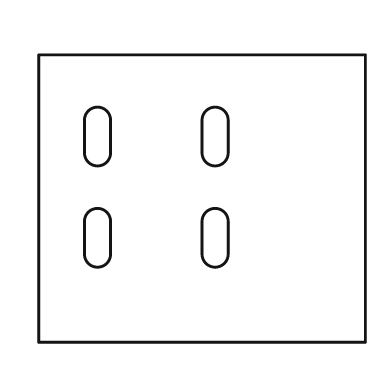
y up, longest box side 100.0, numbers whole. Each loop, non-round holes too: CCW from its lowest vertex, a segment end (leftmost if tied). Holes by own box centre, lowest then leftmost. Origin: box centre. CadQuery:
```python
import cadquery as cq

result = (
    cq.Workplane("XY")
    .moveTo(-50.0, -44.0)
    .lineTo(50.0, -44.0)
    .lineTo(50.0, 44.0)
    .lineTo(-50.0, 44.0)
    .close()
    .moveTo(-36.0, -17.0)
    .threePointArc((-32.0, -21.0), (-28.0, -17.0))
    .lineTo(-28.0, -7.0)
    .threePointArc((-32.0, -3.0), (-36.0, -7.0))
    .close()
    .moveTo(0.0, -17.0)
    .threePointArc((4.0, -21.0), (8.0, -17.0))
    .lineTo(8.0, -7.0)
    .threePointArc((4.0, -3.0), (0.0, -7.0))
    .close()
    .moveTo(-36.0, 14.0)
    .threePointArc((-32.0, 10.0), (-28.0, 14.0))
    .lineTo(-28.0, 24.0)
    .threePointArc((-32.0, 28.0), (-36.0, 24.0))
    .close()
    .moveTo(0.0, 14.0)
    .threePointArc((4.0, 10.0), (8.0, 14.0))
    .lineTo(8.0, 24.0)
    .threePointArc((4.0, 28.0), (0.0, 24.0))
    .close()
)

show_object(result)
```